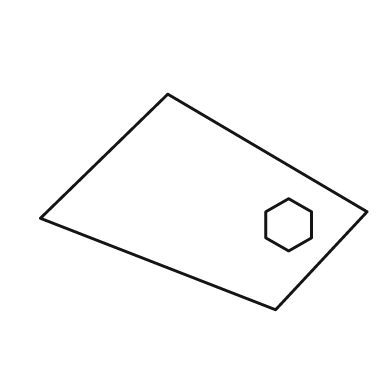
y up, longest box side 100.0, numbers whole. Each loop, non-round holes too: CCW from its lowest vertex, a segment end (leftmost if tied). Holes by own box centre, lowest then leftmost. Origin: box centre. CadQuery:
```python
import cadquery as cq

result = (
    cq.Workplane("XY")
    .moveTo(22.0, -33.0)
    .lineTo(50.0, -3.0)
    .lineTo(-11.0, 33.0)
    .lineTo(-50.0, -5.0)
    .close()
    .moveTo(26.0, -15.0)
    .lineTo(33.0, -11.0)
    .lineTo(33.0, -3.0)
    .lineTo(26.0, 1.0)
    .lineTo(19.0, -3.0)
    .lineTo(19.0, -11.0)
    .close()
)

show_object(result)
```